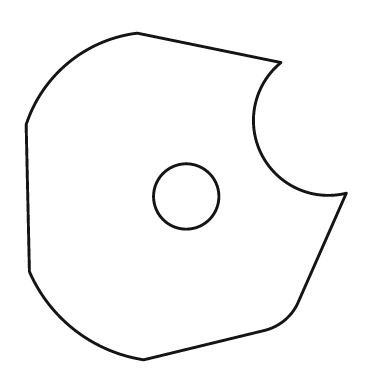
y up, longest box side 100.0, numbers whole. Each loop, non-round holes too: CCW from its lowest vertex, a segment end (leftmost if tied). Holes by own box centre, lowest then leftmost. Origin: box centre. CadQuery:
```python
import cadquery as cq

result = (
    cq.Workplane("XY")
    .moveTo(-13.0, -50.0)
    .lineTo(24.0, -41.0)
    .threePointArc((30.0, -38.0), (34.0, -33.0))
    .lineTo(49.0, 1.0)
    .threePointArc((23.0, 13.0), (29.0, 41.0))
    .lineTo(-15.0, 50.0)
    .threePointArc((-36.0, 41.0), (-49.0, 22.0))
    .lineTo(-48.0, -23.0)
    .threePointArc((-34.0, -41.0), (-13.0, -50.0))
    .close()
    .moveTo(0.0, 0.0)
    .circle(10.0)
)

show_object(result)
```